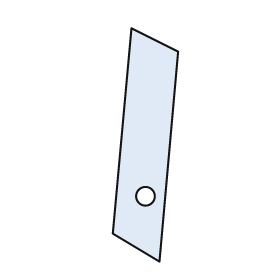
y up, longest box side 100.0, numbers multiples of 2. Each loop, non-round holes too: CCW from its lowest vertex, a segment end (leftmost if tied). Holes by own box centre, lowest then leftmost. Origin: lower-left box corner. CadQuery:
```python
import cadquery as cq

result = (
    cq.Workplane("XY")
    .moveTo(20.0, 0.0)
    .lineTo(28.0, 90.0)
    .lineTo(8.0, 100.0)
    .lineTo(0.0, 12.0)
    .close()
    .moveTo(14.0, 28.0)
    .circle(4.0)
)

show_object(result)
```